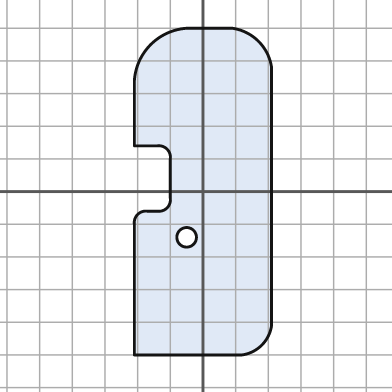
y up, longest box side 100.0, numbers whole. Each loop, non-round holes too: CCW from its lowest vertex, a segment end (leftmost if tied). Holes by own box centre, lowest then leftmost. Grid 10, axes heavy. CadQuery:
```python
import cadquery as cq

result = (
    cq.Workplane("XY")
    .moveTo(-21.0, -50.0)
    .lineTo(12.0, -50.0)
    .threePointArc((18.0, -47.0), (21.0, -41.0))
    .lineTo(21.0, 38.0)
    .threePointArc((17.0, 46.0), (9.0, 50.0))
    .lineTo(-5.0, 50.0)
    .threePointArc((-16.0, 45.0), (-21.0, 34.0))
    .lineTo(-21.0, 14.0)
    .lineTo(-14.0, 14.0)
    .threePointArc((-11.0, 13.0), (-10.0, 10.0))
    .lineTo(-10.0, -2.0)
    .threePointArc((-11.0, -5.0), (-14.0, -6.0))
    .lineTo(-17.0, -6.0)
    .threePointArc((-20.0, -7.0), (-21.0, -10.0))
    .close()
    .moveTo(-5.0, -14.0)
    .circle(3.0)
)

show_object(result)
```